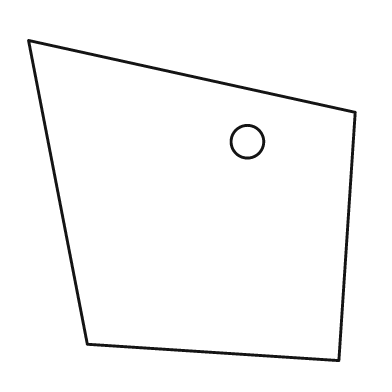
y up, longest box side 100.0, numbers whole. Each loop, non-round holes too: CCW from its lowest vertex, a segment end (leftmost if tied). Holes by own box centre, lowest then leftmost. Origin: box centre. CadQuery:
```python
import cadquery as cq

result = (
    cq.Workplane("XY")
    .moveTo(45.0, -49.0)
    .lineTo(50.0, 27.0)
    .lineTo(-50.0, 49.0)
    .lineTo(-32.0, -44.0)
    .close()
    .moveTo(17.0, 18.0)
    .circle(5.0)
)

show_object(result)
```